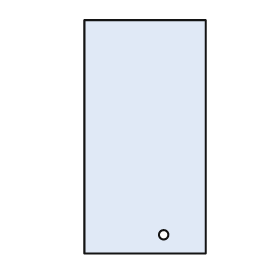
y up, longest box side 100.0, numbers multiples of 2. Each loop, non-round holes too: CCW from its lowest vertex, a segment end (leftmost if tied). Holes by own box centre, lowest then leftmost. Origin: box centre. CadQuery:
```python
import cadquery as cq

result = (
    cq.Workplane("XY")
    .moveTo(-26.0, -50.0)
    .lineTo(26.0, -50.0)
    .lineTo(26.0, 50.0)
    .lineTo(-26.0, 50.0)
    .close()
    .moveTo(8.0, -42.0)
    .circle(2.0)
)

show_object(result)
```